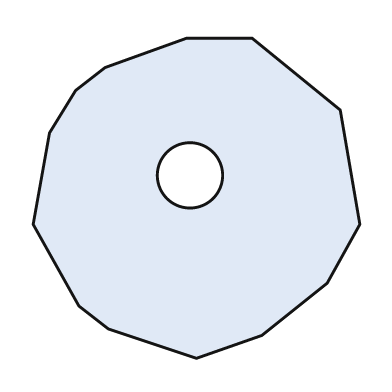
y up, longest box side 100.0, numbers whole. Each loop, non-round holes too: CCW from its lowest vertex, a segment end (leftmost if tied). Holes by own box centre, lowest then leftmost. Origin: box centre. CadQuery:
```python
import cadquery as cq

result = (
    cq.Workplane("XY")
    .moveTo(0.0, -49.0)
    .lineTo(20.0, -42.0)
    .lineTo(40.0, -26.0)
    .lineTo(50.0, -8.0)
    .lineTo(44.0, 27.0)
    .lineTo(17.0, 49.0)
    .lineTo(-3.0, 49.0)
    .lineTo(-28.0, 40.0)
    .lineTo(-37.0, 33.0)
    .lineTo(-45.0, 20.0)
    .lineTo(-50.0, -8.0)
    .lineTo(-36.0, -33.0)
    .lineTo(-27.0, -40.0)
    .close()
    .moveTo(-2.0, 7.0)
    .circle(10.0)
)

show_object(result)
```